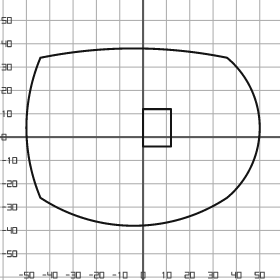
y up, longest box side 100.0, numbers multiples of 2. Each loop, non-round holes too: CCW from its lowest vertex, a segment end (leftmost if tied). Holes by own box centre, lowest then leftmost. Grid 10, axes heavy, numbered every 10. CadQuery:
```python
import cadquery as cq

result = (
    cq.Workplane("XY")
    .moveTo(-44.0, -26.0)
    .threePointArc((-4.0, -38.0), (36.0, -26.0))
    .threePointArc((50.0, 4.0), (36.0, 34.0))
    .threePointArc((-4.0, 38.0), (-44.0, 34.0))
    .threePointArc((-50.0, 4.0), (-44.0, -26.0))
    .close()
    .moveTo(0.0, -4.0)
    .lineTo(12.0, -4.0)
    .lineTo(12.0, 12.0)
    .lineTo(0.0, 12.0)
    .close()
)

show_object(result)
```